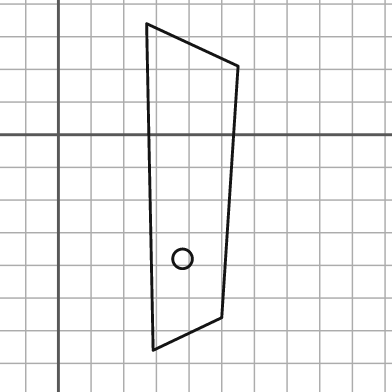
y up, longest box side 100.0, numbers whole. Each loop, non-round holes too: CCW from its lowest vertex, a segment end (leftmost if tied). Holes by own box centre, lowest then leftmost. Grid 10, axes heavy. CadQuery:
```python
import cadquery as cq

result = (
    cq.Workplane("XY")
    .moveTo(29.0, -66.0)
    .lineTo(50.0, -56.0)
    .lineTo(55.0, 21.0)
    .lineTo(27.0, 34.0)
    .close()
    .moveTo(38.0, -38.0)
    .circle(3.0)
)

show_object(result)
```